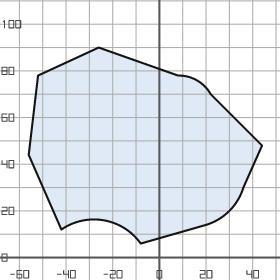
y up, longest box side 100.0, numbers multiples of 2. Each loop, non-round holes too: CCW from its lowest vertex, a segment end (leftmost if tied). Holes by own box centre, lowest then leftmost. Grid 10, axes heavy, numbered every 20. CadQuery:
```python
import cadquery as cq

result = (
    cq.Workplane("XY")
    .moveTo(-8.0, 6.0)
    .lineTo(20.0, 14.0)
    .threePointArc((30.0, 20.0), (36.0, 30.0))
    .lineTo(44.0, 48.0)
    .lineTo(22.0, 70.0)
    .threePointArc((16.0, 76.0), (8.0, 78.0))
    .lineTo(-26.0, 90.0)
    .lineTo(-52.0, 78.0)
    .lineTo(-56.0, 44.0)
    .lineTo(-42.0, 12.0)
    .threePointArc((-24.0, 16.0), (-8.0, 6.0))
    .close()
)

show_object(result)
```